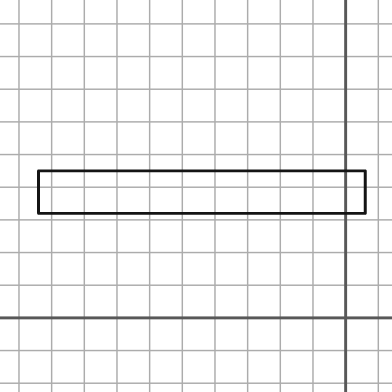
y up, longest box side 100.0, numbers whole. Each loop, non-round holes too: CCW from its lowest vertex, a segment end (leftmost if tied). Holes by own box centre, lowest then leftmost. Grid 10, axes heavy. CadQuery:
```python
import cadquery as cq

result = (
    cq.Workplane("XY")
    .moveTo(-94.0, 32.0)
    .lineTo(6.0, 32.0)
    .lineTo(6.0, 45.0)
    .lineTo(-94.0, 45.0)
    .close()
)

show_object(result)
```